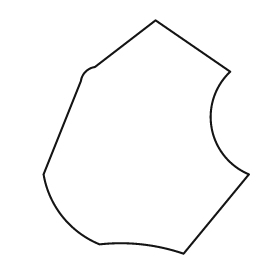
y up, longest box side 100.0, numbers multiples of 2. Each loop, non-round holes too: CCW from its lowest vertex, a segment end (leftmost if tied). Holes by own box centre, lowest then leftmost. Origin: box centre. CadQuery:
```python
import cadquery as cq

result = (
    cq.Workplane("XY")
    .moveTo(16.0, -50.0)
    .lineTo(44.0, -16.0)
    .threePointArc((28.0, 4.0), (36.0, 28.0))
    .lineTo(4.0, 50.0)
    .lineTo(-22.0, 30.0)
    .threePointArc((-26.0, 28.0), (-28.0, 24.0))
    .lineTo(-44.0, -16.0)
    .threePointArc((-36.0, -34.0), (-20.0, -46.0))
    .threePointArc((-2.0, -46.0), (16.0, -50.0))
    .close()
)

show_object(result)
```